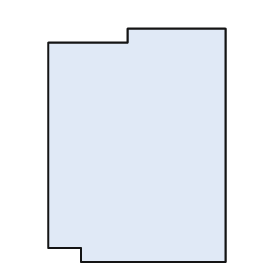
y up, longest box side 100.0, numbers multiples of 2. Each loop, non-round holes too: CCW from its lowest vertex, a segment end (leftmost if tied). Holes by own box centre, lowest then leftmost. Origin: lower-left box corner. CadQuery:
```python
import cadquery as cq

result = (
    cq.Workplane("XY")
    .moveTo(14.0, 0.0)
    .lineTo(76.0, 0.0)
    .lineTo(76.0, 100.0)
    .lineTo(34.0, 100.0)
    .lineTo(34.0, 94.0)
    .lineTo(0.0, 94.0)
    .lineTo(0.0, 6.0)
    .lineTo(14.0, 6.0)
    .close()
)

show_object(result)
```